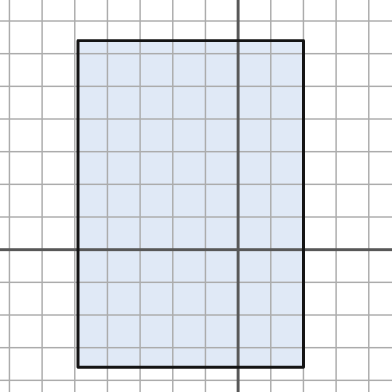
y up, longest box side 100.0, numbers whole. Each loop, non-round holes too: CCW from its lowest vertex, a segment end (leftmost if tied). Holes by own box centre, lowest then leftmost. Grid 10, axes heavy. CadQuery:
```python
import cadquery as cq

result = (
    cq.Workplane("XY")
    .moveTo(-49.0, -36.0)
    .lineTo(20.0, -36.0)
    .lineTo(20.0, 64.0)
    .lineTo(-49.0, 64.0)
    .close()
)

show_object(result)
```